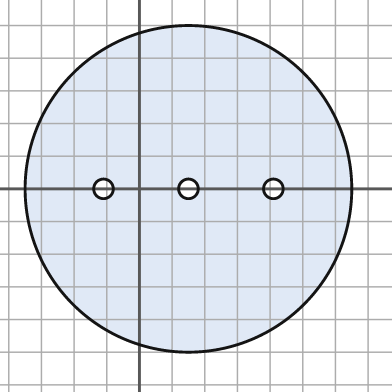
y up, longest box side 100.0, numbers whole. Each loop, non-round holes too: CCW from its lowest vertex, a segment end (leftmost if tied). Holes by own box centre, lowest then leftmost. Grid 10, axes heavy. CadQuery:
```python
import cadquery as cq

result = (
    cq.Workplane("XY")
    .moveTo(15.0, 0.0)
    .circle(50.0)
    .moveTo(-11.0, 0.0)
    .circle(3.0)
    .moveTo(15.0, 0.0)
    .circle(3.0)
    .moveTo(41.0, 0.0)
    .circle(3.0)
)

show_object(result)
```